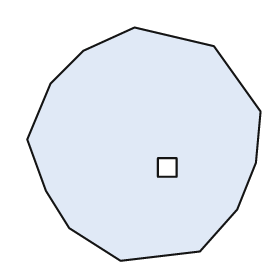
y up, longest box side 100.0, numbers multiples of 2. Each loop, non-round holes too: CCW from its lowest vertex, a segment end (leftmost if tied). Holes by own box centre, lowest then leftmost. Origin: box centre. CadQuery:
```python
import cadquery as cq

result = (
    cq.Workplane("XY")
    .moveTo(-10.0, -50.0)
    .lineTo(24.0, -46.0)
    .lineTo(40.0, -28.0)
    .lineTo(48.0, -8.0)
    .lineTo(50.0, 14.0)
    .lineTo(30.0, 42.0)
    .lineTo(-4.0, 50.0)
    .lineTo(-26.0, 40.0)
    .lineTo(-40.0, 26.0)
    .lineTo(-50.0, 2.0)
    .lineTo(-42.0, -20.0)
    .lineTo(-32.0, -36.0)
    .close()
    .moveTo(6.0, -14.0)
    .lineTo(14.0, -14.0)
    .lineTo(14.0, -6.0)
    .lineTo(6.0, -6.0)
    .close()
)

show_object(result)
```